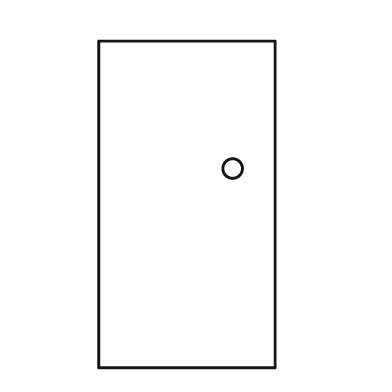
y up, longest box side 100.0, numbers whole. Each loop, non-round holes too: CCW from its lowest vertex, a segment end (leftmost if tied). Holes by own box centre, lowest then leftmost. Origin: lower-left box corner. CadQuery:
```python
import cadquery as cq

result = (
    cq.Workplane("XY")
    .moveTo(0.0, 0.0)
    .lineTo(54.0, 0.0)
    .lineTo(54.0, 100.0)
    .lineTo(0.0, 100.0)
    .close()
    .moveTo(41.0, 61.0)
    .circle(3.0)
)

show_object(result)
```